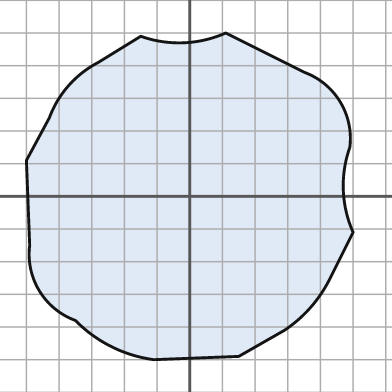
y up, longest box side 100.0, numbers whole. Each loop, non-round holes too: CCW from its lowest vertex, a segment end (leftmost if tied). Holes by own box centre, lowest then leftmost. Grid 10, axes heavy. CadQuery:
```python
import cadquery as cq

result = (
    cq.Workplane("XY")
    .moveTo(-11.0, -50.0)
    .lineTo(15.0, -49.0)
    .lineTo(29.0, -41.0)
    .threePointArc((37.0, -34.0), (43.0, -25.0))
    .lineTo(50.0, -11.0)
    .threePointArc((47.0, 2.0), (49.0, 15.0))
    .threePointArc((46.0, 29.0), (35.0, 38.0))
    .lineTo(11.0, 50.0)
    .threePointArc((-2.0, 47.0), (-15.0, 49.0))
    .lineTo(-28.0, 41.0)
    .threePointArc((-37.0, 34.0), (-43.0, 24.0))
    .lineTo(-50.0, 11.0)
    .lineTo(-49.0, -15.0)
    .threePointArc((-46.0, -29.0), (-35.0, -38.0))
    .threePointArc((-24.0, -46.0), (-11.0, -50.0))
    .close()
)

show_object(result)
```